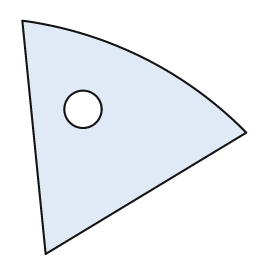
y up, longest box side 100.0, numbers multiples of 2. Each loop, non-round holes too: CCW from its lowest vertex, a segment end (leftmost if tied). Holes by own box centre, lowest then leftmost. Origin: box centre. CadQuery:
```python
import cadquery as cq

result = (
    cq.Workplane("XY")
    .moveTo(-38.0, -50.0)
    .lineTo(48.0, 2.0)
    .threePointArc((4.0, 34.0), (-48.0, 50.0))
    .close()
    .moveTo(-22.0, 12.0)
    .circle(8.0)
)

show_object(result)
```